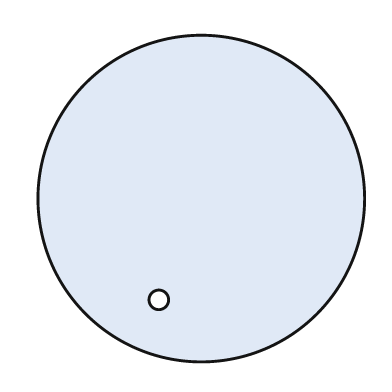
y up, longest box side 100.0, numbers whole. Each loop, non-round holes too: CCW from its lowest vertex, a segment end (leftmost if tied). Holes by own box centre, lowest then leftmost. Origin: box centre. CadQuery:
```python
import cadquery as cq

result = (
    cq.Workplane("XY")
    .moveTo(0.0, 0.0)
    .circle(50.0)
    .moveTo(-13.0, -31.0)
    .circle(3.0)
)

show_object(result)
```